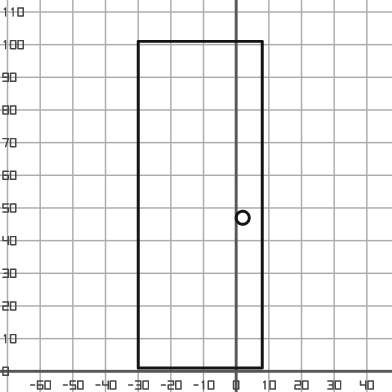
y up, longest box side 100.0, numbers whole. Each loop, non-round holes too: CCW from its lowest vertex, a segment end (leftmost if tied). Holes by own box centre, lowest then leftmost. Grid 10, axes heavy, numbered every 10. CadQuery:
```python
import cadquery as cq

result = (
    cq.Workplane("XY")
    .moveTo(-30.0, 1.0)
    .lineTo(8.0, 1.0)
    .lineTo(8.0, 101.0)
    .lineTo(-30.0, 101.0)
    .close()
    .moveTo(2.0, 47.0)
    .circle(2.0)
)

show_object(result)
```